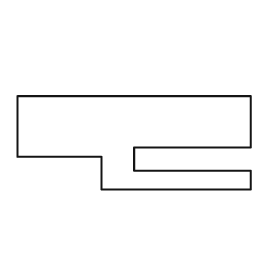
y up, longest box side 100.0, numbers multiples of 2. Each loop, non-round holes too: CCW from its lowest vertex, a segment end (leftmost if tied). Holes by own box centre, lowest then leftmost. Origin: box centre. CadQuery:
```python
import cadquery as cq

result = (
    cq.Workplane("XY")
    .moveTo(-14.0, -20.0)
    .lineTo(50.0, -20.0)
    .lineTo(50.0, -12.0)
    .lineTo(0.0, -12.0)
    .lineTo(0.0, -2.0)
    .lineTo(50.0, -2.0)
    .lineTo(50.0, 20.0)
    .lineTo(-50.0, 20.0)
    .lineTo(-50.0, -6.0)
    .lineTo(-14.0, -6.0)
    .close()
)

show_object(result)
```